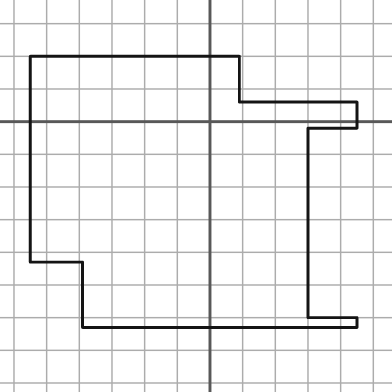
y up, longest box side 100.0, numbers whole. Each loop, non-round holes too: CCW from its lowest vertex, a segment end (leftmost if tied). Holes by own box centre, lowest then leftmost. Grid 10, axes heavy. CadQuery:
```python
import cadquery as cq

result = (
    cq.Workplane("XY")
    .moveTo(-39.0, -63.0)
    .lineTo(45.0, -63.0)
    .lineTo(45.0, -60.0)
    .lineTo(30.0, -60.0)
    .lineTo(30.0, -2.0)
    .lineTo(45.0, -2.0)
    .lineTo(45.0, 6.0)
    .lineTo(9.0, 6.0)
    .lineTo(9.0, 20.0)
    .lineTo(-55.0, 20.0)
    .lineTo(-55.0, -43.0)
    .lineTo(-39.0, -43.0)
    .close()
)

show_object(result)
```